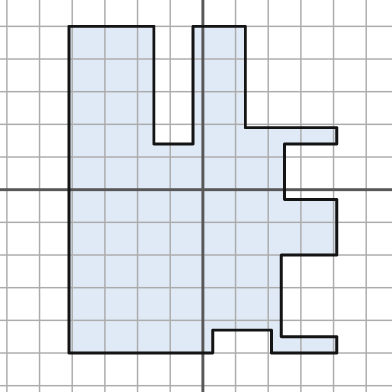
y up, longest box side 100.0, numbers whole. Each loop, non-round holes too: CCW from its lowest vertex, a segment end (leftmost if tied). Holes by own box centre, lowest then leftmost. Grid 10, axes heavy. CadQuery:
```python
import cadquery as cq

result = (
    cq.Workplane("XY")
    .moveTo(-41.0, -50.0)
    .lineTo(3.0, -50.0)
    .lineTo(3.0, -43.0)
    .lineTo(21.0, -43.0)
    .lineTo(21.0, -50.0)
    .lineTo(41.0, -50.0)
    .lineTo(41.0, -45.0)
    .lineTo(24.0, -45.0)
    .lineTo(24.0, -20.0)
    .lineTo(41.0, -20.0)
    .lineTo(41.0, -3.0)
    .lineTo(25.0, -3.0)
    .lineTo(25.0, 14.0)
    .lineTo(41.0, 14.0)
    .lineTo(41.0, 19.0)
    .lineTo(13.0, 19.0)
    .lineTo(13.0, 50.0)
    .lineTo(-3.0, 50.0)
    .lineTo(-3.0, 14.0)
    .lineTo(-15.0, 14.0)
    .lineTo(-15.0, 50.0)
    .lineTo(-41.0, 50.0)
    .close()
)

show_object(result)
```